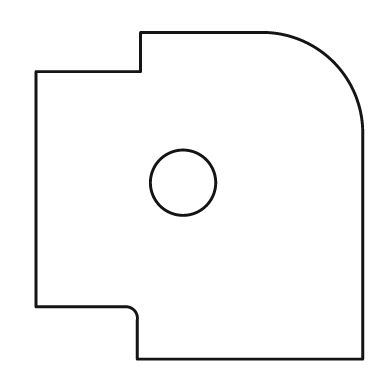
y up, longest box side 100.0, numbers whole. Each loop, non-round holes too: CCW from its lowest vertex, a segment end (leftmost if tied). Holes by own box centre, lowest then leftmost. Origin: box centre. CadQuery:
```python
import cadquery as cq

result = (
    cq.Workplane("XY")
    .moveTo(-19.0, -50.0)
    .lineTo(50.0, -50.0)
    .lineTo(50.0, 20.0)
    .threePointArc((41.0, 41.0), (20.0, 50.0))
    .lineTo(-18.0, 50.0)
    .lineTo(-18.0, 38.0)
    .lineTo(-50.0, 38.0)
    .lineTo(-50.0, -34.0)
    .lineTo(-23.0, -34.0)
    .threePointArc((-20.0, -35.0), (-19.0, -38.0))
    .close()
    .moveTo(-5.0, 4.0)
    .circle(10.0)
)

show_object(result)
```